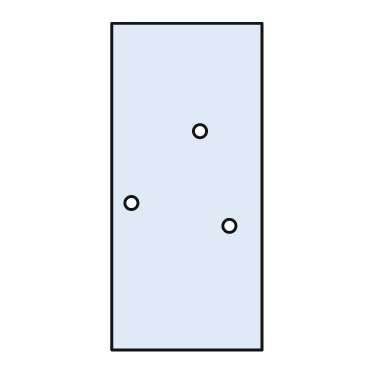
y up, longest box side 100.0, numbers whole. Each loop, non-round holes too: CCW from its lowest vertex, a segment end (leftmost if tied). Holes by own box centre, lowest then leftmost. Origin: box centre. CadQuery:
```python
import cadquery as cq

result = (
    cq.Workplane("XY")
    .moveTo(-23.0, -50.0)
    .lineTo(23.0, -50.0)
    .lineTo(23.0, 50.0)
    .lineTo(-23.0, 50.0)
    .close()
    .moveTo(13.0, -12.0)
    .circle(2.0)
    .moveTo(-17.0, -5.0)
    .circle(2.0)
    .moveTo(4.0, 17.0)
    .circle(2.0)
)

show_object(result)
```